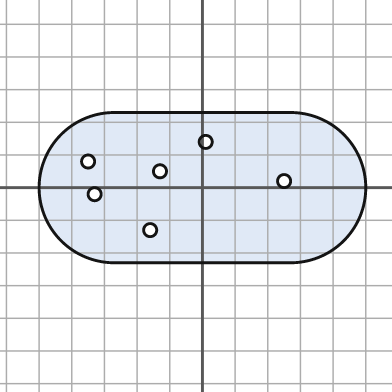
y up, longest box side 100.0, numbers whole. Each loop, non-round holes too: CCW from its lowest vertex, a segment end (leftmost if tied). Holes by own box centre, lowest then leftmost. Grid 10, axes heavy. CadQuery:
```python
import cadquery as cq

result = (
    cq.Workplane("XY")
    .moveTo(-27.0, -23.0)
    .lineTo(27.0, -23.0)
    .threePointArc((50.0, 0.0), (27.0, 23.0))
    .lineTo(-27.0, 23.0)
    .threePointArc((-50.0, 0.0), (-27.0, -23.0))
    .close()
    .moveTo(-16.0, -13.0)
    .circle(2.0)
    .moveTo(-33.0, -2.0)
    .circle(2.0)
    .moveTo(25.0, 2.0)
    .circle(2.0)
    .moveTo(-13.0, 5.0)
    .circle(2.0)
    .moveTo(-35.0, 8.0)
    .circle(2.0)
    .moveTo(1.0, 14.0)
    .circle(2.0)
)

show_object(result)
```